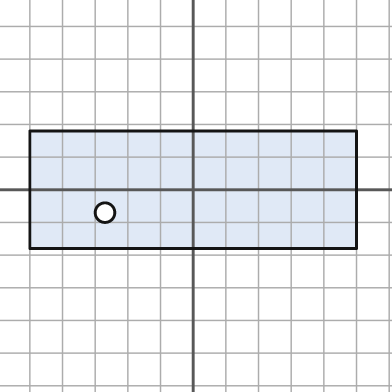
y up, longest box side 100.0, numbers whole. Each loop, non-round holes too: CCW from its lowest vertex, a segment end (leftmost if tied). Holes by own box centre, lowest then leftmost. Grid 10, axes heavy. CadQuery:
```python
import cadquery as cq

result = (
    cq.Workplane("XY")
    .moveTo(-50.0, -18.0)
    .lineTo(50.0, -18.0)
    .lineTo(50.0, 18.0)
    .lineTo(-50.0, 18.0)
    .close()
    .moveTo(-27.0, -7.0)
    .circle(3.0)
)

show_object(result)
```